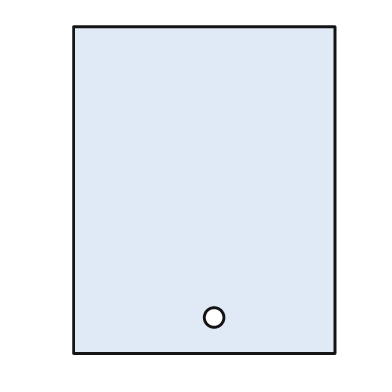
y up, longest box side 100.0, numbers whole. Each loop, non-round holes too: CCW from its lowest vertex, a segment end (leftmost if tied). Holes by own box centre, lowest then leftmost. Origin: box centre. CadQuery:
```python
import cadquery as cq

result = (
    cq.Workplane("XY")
    .moveTo(-40.0, -50.0)
    .lineTo(40.0, -50.0)
    .lineTo(40.0, 50.0)
    .lineTo(-40.0, 50.0)
    .close()
    .moveTo(3.0, -39.0)
    .circle(3.0)
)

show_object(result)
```